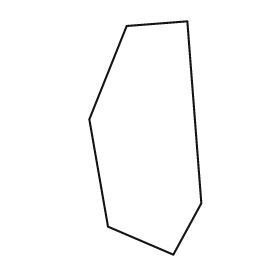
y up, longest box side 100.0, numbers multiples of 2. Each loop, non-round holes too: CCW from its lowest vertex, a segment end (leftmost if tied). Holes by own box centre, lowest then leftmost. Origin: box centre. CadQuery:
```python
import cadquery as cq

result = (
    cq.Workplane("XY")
    .moveTo(12.0, -50.0)
    .lineTo(24.0, -28.0)
    .lineTo(18.0, 50.0)
    .lineTo(-8.0, 48.0)
    .lineTo(-24.0, 8.0)
    .lineTo(-16.0, -38.0)
    .close()
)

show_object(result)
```